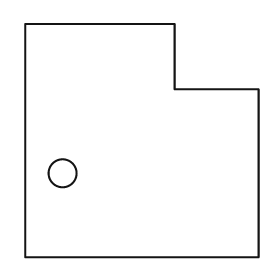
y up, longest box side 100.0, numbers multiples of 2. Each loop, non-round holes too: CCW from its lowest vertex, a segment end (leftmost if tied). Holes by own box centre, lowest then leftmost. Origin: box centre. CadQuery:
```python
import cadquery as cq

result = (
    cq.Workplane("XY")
    .moveTo(-50.0, -50.0)
    .lineTo(50.0, -50.0)
    .lineTo(50.0, 22.0)
    .lineTo(14.0, 22.0)
    .lineTo(14.0, 50.0)
    .lineTo(-50.0, 50.0)
    .close()
    .moveTo(-34.0, -14.0)
    .circle(6.0)
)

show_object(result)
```